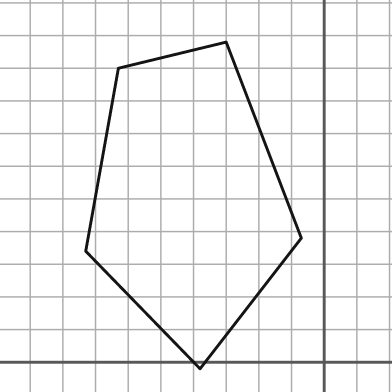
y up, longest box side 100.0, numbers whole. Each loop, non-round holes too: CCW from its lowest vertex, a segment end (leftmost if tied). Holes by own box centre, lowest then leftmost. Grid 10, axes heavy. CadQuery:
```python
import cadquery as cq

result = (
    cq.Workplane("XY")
    .moveTo(-38.0, -2.0)
    .lineTo(-7.0, 38.0)
    .lineTo(-30.0, 98.0)
    .lineTo(-63.0, 90.0)
    .lineTo(-73.0, 34.0)
    .close()
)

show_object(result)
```